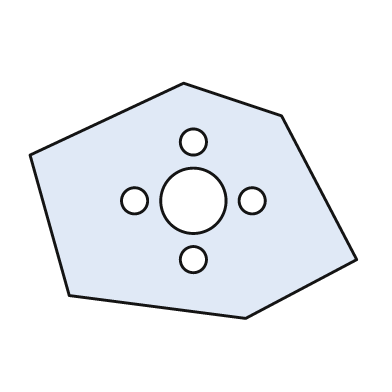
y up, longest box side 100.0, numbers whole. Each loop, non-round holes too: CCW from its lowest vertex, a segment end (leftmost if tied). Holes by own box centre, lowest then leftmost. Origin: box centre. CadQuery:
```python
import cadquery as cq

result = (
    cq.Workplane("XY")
    .moveTo(16.0, -36.0)
    .lineTo(50.0, -18.0)
    .lineTo(27.0, 26.0)
    .lineTo(-3.0, 36.0)
    .lineTo(-50.0, 14.0)
    .lineTo(-38.0, -29.0)
    .close()
    .moveTo(0.0, -18.0)
    .circle(4.0)
    .moveTo(-18.0, 0.0)
    .circle(4.0)
    .moveTo(0.0, 0.0)
    .circle(10.0)
    .moveTo(18.0, 0.0)
    .circle(4.0)
    .moveTo(0.0, 18.0)
    .circle(4.0)
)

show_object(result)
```